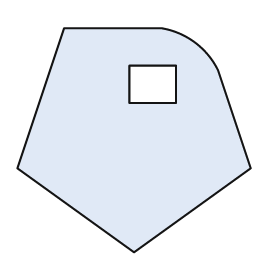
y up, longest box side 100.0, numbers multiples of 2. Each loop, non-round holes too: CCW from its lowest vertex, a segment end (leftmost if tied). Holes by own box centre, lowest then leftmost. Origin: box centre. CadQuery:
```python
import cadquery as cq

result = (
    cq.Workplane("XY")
    .moveTo(0.0, -48.0)
    .lineTo(50.0, -12.0)
    .lineTo(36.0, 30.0)
    .threePointArc((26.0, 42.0), (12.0, 48.0))
    .lineTo(-30.0, 48.0)
    .lineTo(-50.0, -12.0)
    .close()
    .moveTo(-2.0, 16.0)
    .lineTo(18.0, 16.0)
    .lineTo(18.0, 32.0)
    .lineTo(-2.0, 32.0)
    .close()
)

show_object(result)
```